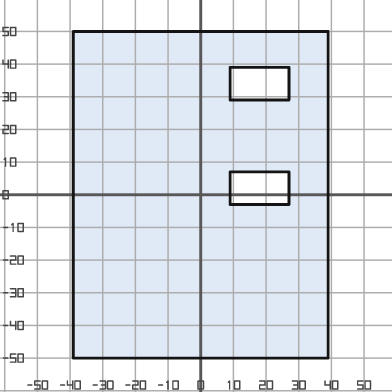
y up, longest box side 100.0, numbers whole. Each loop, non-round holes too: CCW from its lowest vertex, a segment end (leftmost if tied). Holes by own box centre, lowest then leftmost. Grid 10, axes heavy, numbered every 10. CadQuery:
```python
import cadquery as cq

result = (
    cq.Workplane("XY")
    .moveTo(-39.0, -50.0)
    .lineTo(39.0, -50.0)
    .lineTo(39.0, 50.0)
    .lineTo(-39.0, 50.0)
    .close()
    .moveTo(9.0, -3.0)
    .lineTo(27.0, -3.0)
    .lineTo(27.0, 7.0)
    .lineTo(9.0, 7.0)
    .close()
    .moveTo(9.0, 29.0)
    .lineTo(27.0, 29.0)
    .lineTo(27.0, 39.0)
    .lineTo(9.0, 39.0)
    .close()
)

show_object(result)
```